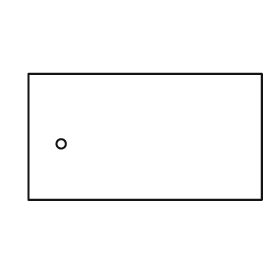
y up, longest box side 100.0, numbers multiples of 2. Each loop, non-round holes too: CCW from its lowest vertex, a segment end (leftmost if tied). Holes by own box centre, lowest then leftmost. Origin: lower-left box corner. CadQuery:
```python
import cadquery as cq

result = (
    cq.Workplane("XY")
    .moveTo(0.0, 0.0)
    .lineTo(100.0, 0.0)
    .lineTo(100.0, 54.0)
    .lineTo(0.0, 54.0)
    .close()
    .moveTo(14.0, 24.0)
    .circle(2.0)
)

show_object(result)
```